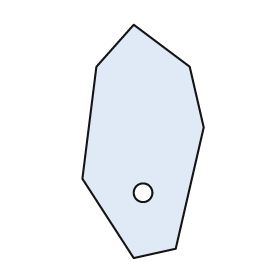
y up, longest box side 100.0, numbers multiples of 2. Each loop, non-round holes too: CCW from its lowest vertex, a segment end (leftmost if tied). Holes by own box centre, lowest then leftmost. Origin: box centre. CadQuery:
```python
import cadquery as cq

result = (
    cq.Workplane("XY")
    .moveTo(-4.0, -50.0)
    .lineTo(14.0, -46.0)
    .lineTo(26.0, 6.0)
    .lineTo(20.0, 32.0)
    .lineTo(-4.0, 50.0)
    .lineTo(-20.0, 32.0)
    .lineTo(-26.0, -16.0)
    .close()
    .moveTo(0.0, -22.0)
    .circle(4.0)
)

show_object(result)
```